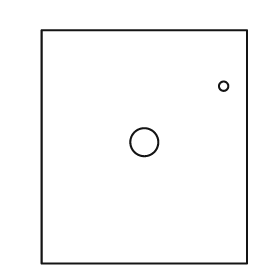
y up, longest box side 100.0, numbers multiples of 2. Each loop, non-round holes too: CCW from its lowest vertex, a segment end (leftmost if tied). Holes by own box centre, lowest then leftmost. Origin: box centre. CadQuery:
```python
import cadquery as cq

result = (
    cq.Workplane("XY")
    .moveTo(-44.0, -50.0)
    .lineTo(44.0, -50.0)
    .lineTo(44.0, 50.0)
    .lineTo(-44.0, 50.0)
    .close()
    .moveTo(0.0, 2.0)
    .circle(6.0)
    .moveTo(34.0, 26.0)
    .circle(2.0)
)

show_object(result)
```